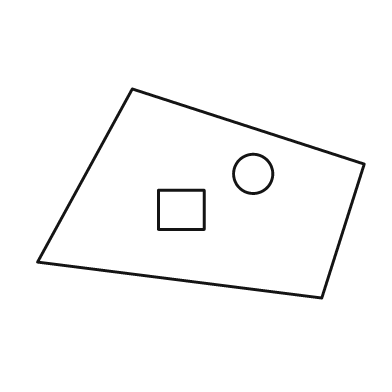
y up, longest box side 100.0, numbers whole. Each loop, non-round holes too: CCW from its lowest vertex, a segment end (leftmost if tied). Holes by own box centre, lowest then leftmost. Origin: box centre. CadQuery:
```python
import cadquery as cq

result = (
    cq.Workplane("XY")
    .moveTo(37.0, -32.0)
    .lineTo(50.0, 9.0)
    .lineTo(-21.0, 32.0)
    .lineTo(-50.0, -21.0)
    .close()
    .moveTo(-13.0, -11.0)
    .lineTo(1.0, -11.0)
    .lineTo(1.0, 1.0)
    .lineTo(-13.0, 1.0)
    .close()
    .moveTo(16.0, 6.0)
    .circle(6.0)
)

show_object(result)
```